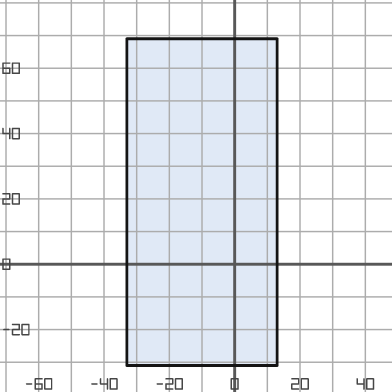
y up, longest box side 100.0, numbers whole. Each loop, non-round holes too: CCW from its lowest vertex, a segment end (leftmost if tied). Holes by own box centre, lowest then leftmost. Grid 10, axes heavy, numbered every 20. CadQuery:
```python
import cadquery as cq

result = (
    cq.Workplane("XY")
    .moveTo(-33.0, -31.0)
    .lineTo(13.0, -31.0)
    .lineTo(13.0, 69.0)
    .lineTo(-33.0, 69.0)
    .close()
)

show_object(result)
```